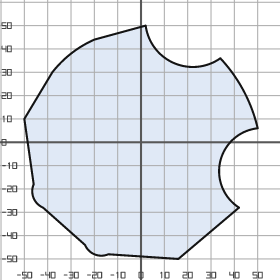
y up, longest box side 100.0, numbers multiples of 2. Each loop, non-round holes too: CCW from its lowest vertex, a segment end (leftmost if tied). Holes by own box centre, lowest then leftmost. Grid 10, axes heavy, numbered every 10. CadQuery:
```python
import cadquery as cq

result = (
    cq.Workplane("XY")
    .moveTo(16.0, -50.0)
    .lineTo(42.0, -28.0)
    .threePointArc((34.0, -8.0), (50.0, 6.0))
    .threePointArc((44.0, 22.0), (34.0, 36.0))
    .threePointArc((14.0, 34.0), (2.0, 50.0))
    .lineTo(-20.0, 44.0)
    .threePointArc((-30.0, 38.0), (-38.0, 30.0))
    .lineTo(-50.0, 10.0)
    .lineTo(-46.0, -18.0)
    .threePointArc((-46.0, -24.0), (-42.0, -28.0))
    .lineTo(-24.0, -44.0)
    .threePointArc((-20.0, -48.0), (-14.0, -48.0))
    .close()
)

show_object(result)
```